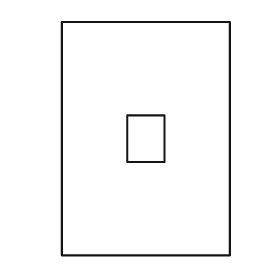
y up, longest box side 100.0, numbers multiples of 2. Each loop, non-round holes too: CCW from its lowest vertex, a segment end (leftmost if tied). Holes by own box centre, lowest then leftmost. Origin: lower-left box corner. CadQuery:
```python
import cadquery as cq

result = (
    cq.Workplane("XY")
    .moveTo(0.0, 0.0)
    .lineTo(72.0, 0.0)
    .lineTo(72.0, 100.0)
    .lineTo(0.0, 100.0)
    .close()
    .moveTo(28.0, 40.0)
    .lineTo(44.0, 40.0)
    .lineTo(44.0, 60.0)
    .lineTo(28.0, 60.0)
    .close()
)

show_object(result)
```